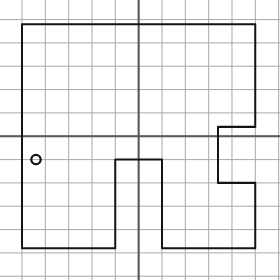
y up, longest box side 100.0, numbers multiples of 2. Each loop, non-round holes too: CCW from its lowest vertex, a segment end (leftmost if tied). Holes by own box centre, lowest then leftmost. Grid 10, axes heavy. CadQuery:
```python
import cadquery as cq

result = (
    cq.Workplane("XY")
    .moveTo(-50.0, -48.0)
    .lineTo(-10.0, -48.0)
    .lineTo(-10.0, -10.0)
    .lineTo(10.0, -10.0)
    .lineTo(10.0, -48.0)
    .lineTo(50.0, -48.0)
    .lineTo(50.0, -20.0)
    .lineTo(34.0, -20.0)
    .lineTo(34.0, 4.0)
    .lineTo(50.0, 4.0)
    .lineTo(50.0, 48.0)
    .lineTo(-50.0, 48.0)
    .close()
    .moveTo(-44.0, -10.0)
    .circle(2.0)
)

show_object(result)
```